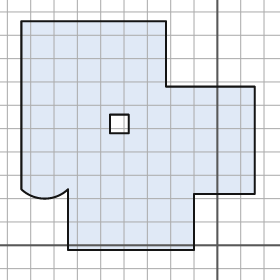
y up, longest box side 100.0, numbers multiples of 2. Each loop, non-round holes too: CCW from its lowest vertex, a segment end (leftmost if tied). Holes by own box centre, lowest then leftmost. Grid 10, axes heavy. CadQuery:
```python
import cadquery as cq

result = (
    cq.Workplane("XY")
    .moveTo(-64.0, -2.0)
    .lineTo(-10.0, -2.0)
    .lineTo(-10.0, 22.0)
    .lineTo(16.0, 22.0)
    .lineTo(16.0, 68.0)
    .lineTo(-22.0, 68.0)
    .lineTo(-22.0, 96.0)
    .lineTo(-84.0, 96.0)
    .lineTo(-84.0, 24.0)
    .threePointArc((-74.0, 20.0), (-64.0, 24.0))
    .close()
    .moveTo(-46.0, 48.0)
    .lineTo(-38.0, 48.0)
    .lineTo(-38.0, 56.0)
    .lineTo(-46.0, 56.0)
    .close()
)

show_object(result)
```